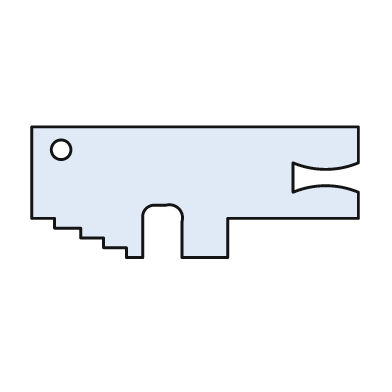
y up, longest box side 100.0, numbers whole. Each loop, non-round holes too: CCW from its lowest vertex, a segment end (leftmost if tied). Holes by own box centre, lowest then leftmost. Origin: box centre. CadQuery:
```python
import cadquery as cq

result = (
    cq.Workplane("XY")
    .moveTo(-21.0, -20.0)
    .lineTo(-16.0, -20.0)
    .lineTo(-16.0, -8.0)
    .threePointArc((-15.0, -5.0), (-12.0, -4.0))
    .lineTo(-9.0, -4.0)
    .threePointArc((-5.0, -5.0), (-4.0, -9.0))
    .lineTo(-4.0, -20.0)
    .lineTo(10.0, -20.0)
    .lineTo(10.0, -8.0)
    .lineTo(50.0, -8.0)
    .lineTo(50.0, 0.0)
    .threePointArc((40.0, 2.0), (30.0, 0.0))
    .lineTo(30.0, 9.0)
    .threePointArc((40.0, 7.0), (50.0, 9.0))
    .lineTo(50.0, 20.0)
    .lineTo(-50.0, 20.0)
    .lineTo(-50.0, -8.0)
    .lineTo(-43.0, -8.0)
    .lineTo(-43.0, -11.0)
    .lineTo(-35.0, -11.0)
    .lineTo(-35.0, -14.0)
    .lineTo(-28.0, -14.0)
    .lineTo(-28.0, -17.0)
    .lineTo(-21.0, -17.0)
    .close()
    .moveTo(-41.0, 13.0)
    .circle(3.0)
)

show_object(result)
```